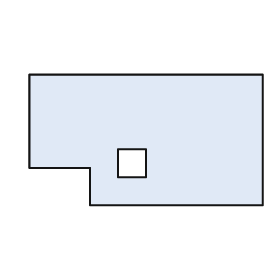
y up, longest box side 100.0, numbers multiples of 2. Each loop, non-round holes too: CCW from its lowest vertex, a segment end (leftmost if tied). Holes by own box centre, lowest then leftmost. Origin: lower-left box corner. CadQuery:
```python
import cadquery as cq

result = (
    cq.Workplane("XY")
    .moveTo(26.0, 0.0)
    .lineTo(100.0, 0.0)
    .lineTo(100.0, 56.0)
    .lineTo(0.0, 56.0)
    .lineTo(0.0, 16.0)
    .lineTo(26.0, 16.0)
    .close()
    .moveTo(38.0, 12.0)
    .lineTo(50.0, 12.0)
    .lineTo(50.0, 24.0)
    .lineTo(38.0, 24.0)
    .close()
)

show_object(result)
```